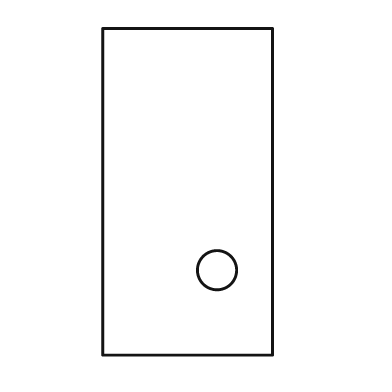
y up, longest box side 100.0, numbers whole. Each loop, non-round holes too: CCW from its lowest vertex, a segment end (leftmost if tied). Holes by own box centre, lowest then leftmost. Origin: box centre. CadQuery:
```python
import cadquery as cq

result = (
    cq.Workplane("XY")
    .moveTo(-26.0, -50.0)
    .lineTo(26.0, -50.0)
    .lineTo(26.0, 50.0)
    .lineTo(-26.0, 50.0)
    .close()
    .moveTo(9.0, -24.0)
    .circle(6.0)
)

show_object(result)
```